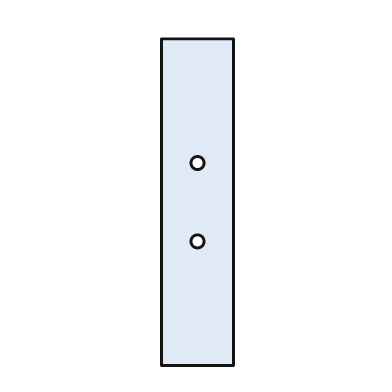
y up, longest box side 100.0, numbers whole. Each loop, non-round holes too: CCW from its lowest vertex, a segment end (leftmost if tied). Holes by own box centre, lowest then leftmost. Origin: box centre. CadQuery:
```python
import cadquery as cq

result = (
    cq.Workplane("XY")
    .moveTo(-11.0, -50.0)
    .lineTo(11.0, -50.0)
    .lineTo(11.0, 50.0)
    .lineTo(-11.0, 50.0)
    .close()
    .moveTo(0.0, -12.0)
    .circle(2.0)
    .moveTo(0.0, 12.0)
    .circle(2.0)
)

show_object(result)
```